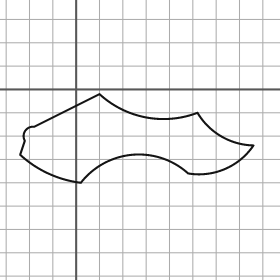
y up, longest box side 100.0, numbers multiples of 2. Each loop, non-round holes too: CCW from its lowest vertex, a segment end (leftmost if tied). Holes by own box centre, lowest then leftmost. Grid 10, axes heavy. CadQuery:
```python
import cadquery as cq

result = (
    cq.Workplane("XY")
    .moveTo(2.0, -40.0)
    .threePointArc((24.0, -28.0), (48.0, -36.0))
    .threePointArc((64.0, -34.0), (76.0, -24.0))
    .threePointArc((62.0, -20.0), (52.0, -10.0))
    .threePointArc((30.0, -12.0), (10.0, -2.0))
    .lineTo(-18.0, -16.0)
    .threePointArc((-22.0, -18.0), (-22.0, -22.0))
    .lineTo(-24.0, -28.0)
    .threePointArc((-12.0, -36.0), (2.0, -40.0))
    .close()
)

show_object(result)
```